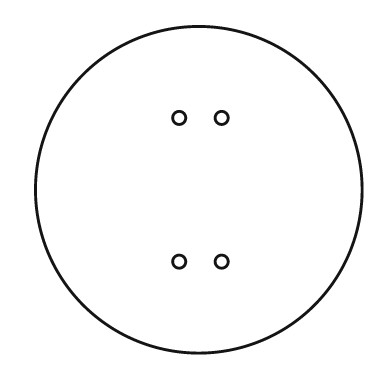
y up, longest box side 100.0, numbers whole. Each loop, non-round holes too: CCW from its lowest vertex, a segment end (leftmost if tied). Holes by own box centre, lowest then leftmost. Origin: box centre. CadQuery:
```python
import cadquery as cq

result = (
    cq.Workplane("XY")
    .moveTo(0.0, 0.0)
    .circle(50.0)
    .moveTo(-6.0, -22.0)
    .circle(2.0)
    .moveTo(7.0, -22.0)
    .circle(2.0)
    .moveTo(-6.0, 22.0)
    .circle(2.0)
    .moveTo(7.0, 22.0)
    .circle(2.0)
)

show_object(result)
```